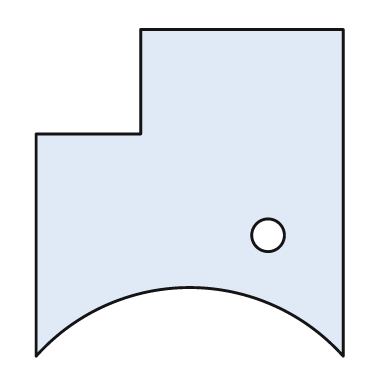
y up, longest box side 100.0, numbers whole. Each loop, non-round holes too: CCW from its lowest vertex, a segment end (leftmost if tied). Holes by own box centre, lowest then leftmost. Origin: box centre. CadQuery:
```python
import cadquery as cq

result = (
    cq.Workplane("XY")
    .moveTo(-47.0, -50.0)
    .threePointArc((0.0, -29.0), (47.0, -50.0))
    .lineTo(47.0, 50.0)
    .lineTo(-15.0, 50.0)
    .lineTo(-15.0, 18.0)
    .lineTo(-47.0, 18.0)
    .close()
    .moveTo(24.0, -13.0)
    .circle(5.0)
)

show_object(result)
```